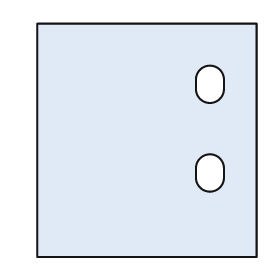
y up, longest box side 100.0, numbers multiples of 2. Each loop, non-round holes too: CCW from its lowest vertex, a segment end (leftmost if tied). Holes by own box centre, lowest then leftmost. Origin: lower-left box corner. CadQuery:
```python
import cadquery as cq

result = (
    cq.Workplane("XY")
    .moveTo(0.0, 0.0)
    .lineTo(94.0, 0.0)
    .lineTo(94.0, 100.0)
    .lineTo(0.0, 100.0)
    .close()
    .moveTo(68.0, 34.0)
    .threePointArc((74.0, 28.0), (80.0, 34.0))
    .lineTo(80.0, 38.0)
    .threePointArc((74.0, 44.0), (68.0, 38.0))
    .close()
    .moveTo(68.0, 72.0)
    .threePointArc((74.0, 66.0), (80.0, 72.0))
    .lineTo(80.0, 76.0)
    .threePointArc((74.0, 82.0), (68.0, 76.0))
    .close()
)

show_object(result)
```